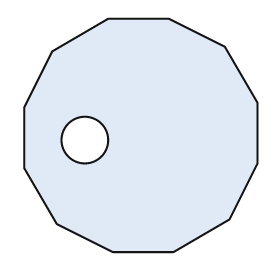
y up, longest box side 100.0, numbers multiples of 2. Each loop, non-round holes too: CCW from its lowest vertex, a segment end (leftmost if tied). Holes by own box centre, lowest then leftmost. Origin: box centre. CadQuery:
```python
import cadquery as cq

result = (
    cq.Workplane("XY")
    .moveTo(-12.0, -50.0)
    .lineTo(14.0, -50.0)
    .lineTo(38.0, -36.0)
    .lineTo(50.0, -12.0)
    .lineTo(50.0, 14.0)
    .lineTo(36.0, 38.0)
    .lineTo(12.0, 50.0)
    .lineTo(-14.0, 50.0)
    .lineTo(-38.0, 36.0)
    .lineTo(-50.0, 12.0)
    .lineTo(-50.0, -14.0)
    .lineTo(-36.0, -38.0)
    .close()
    .moveTo(-24.0, -2.0)
    .circle(10.0)
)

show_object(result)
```